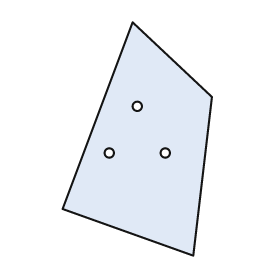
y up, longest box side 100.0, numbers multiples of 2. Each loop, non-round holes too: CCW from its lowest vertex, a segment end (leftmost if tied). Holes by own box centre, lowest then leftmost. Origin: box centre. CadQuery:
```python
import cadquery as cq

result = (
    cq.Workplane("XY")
    .moveTo(24.0, -50.0)
    .lineTo(32.0, 18.0)
    .lineTo(-2.0, 50.0)
    .lineTo(-32.0, -30.0)
    .close()
    .moveTo(-12.0, -6.0)
    .circle(2.0)
    .moveTo(12.0, -6.0)
    .circle(2.0)
    .moveTo(0.0, 14.0)
    .circle(2.0)
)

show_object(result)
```